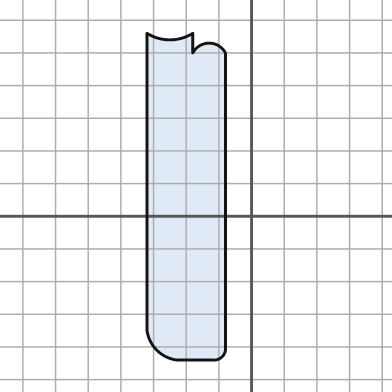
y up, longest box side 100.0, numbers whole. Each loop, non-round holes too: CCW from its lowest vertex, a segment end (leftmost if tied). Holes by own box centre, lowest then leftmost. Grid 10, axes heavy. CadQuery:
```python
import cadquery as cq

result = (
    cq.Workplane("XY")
    .moveTo(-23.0, -44.0)
    .lineTo(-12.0, -44.0)
    .threePointArc((-9.0, -43.0), (-8.0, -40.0))
    .lineTo(-8.0, 50.0)
    .threePointArc((-13.0, 53.0), (-18.0, 50.0))
    .lineTo(-18.0, 56.0)
    .threePointArc((-25.0, 54.0), (-32.0, 56.0))
    .lineTo(-32.0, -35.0)
    .threePointArc((-29.0, -41.0), (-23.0, -44.0))
    .close()
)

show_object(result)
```